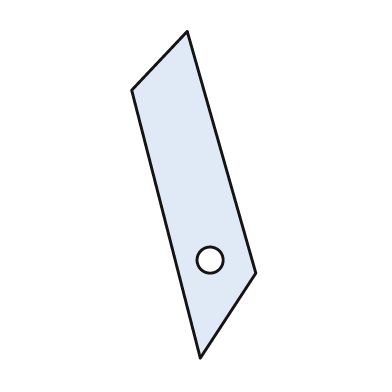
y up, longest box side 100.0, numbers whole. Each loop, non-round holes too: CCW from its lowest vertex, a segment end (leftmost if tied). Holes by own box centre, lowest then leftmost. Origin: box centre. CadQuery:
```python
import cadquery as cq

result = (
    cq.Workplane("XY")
    .moveTo(2.0, -50.0)
    .lineTo(19.0, -24.0)
    .lineTo(-2.0, 50.0)
    .lineTo(-19.0, 32.0)
    .close()
    .moveTo(5.0, -20.0)
    .circle(4.0)
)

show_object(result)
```